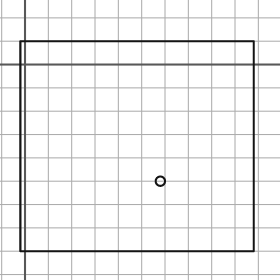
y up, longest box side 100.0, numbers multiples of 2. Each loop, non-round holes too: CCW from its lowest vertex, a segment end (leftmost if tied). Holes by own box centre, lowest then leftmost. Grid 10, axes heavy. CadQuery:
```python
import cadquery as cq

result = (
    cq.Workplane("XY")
    .moveTo(-2.0, -80.0)
    .lineTo(98.0, -80.0)
    .lineTo(98.0, 10.0)
    .lineTo(-2.0, 10.0)
    .close()
    .moveTo(58.0, -50.0)
    .circle(2.0)
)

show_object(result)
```